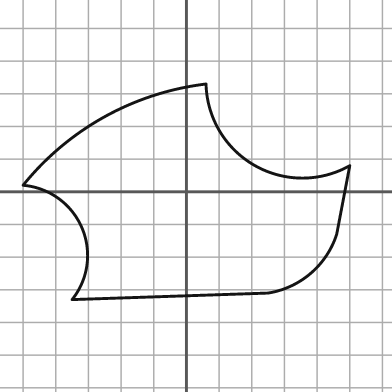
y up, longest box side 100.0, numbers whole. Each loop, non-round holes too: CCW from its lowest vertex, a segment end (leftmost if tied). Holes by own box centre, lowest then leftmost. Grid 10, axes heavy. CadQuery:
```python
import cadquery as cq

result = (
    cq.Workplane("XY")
    .moveTo(-35.0, -33.0)
    .lineTo(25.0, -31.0)
    .threePointArc((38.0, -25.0), (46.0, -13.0))
    .lineTo(50.0, 8.0)
    .threePointArc((21.0, 8.0), (6.0, 33.0))
    .threePointArc((-25.0, 23.0), (-50.0, 2.0))
    .threePointArc((-32.0, -11.0), (-35.0, -33.0))
    .close()
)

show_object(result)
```